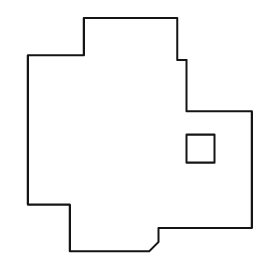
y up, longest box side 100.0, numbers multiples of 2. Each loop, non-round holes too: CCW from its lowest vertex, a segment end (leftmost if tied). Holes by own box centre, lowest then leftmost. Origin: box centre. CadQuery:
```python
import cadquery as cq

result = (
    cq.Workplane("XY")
    .moveTo(-30.0, -50.0)
    .lineTo(4.0, -50.0)
    .lineTo(8.0, -46.0)
    .lineTo(8.0, -40.0)
    .lineTo(48.0, -40.0)
    .lineTo(48.0, 10.0)
    .lineTo(20.0, 10.0)
    .lineTo(20.0, 32.0)
    .lineTo(16.0, 32.0)
    .lineTo(16.0, 50.0)
    .lineTo(-24.0, 50.0)
    .lineTo(-24.0, 34.0)
    .lineTo(-48.0, 34.0)
    .lineTo(-48.0, -30.0)
    .lineTo(-30.0, -30.0)
    .close()
    .moveTo(20.0, -12.0)
    .lineTo(32.0, -12.0)
    .lineTo(32.0, 0.0)
    .lineTo(20.0, 0.0)
    .close()
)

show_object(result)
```